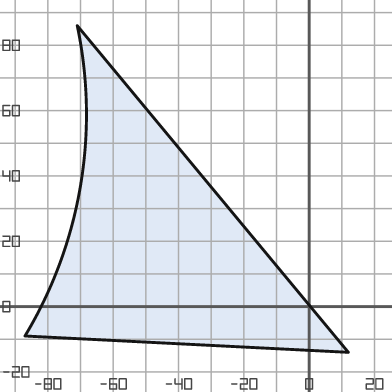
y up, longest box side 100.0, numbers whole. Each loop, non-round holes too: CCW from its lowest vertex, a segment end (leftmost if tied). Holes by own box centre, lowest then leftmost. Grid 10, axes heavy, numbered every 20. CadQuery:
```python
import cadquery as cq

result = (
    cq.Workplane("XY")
    .moveTo(12.0, -14.0)
    .lineTo(-71.0, 86.0)
    .threePointArc((-70.0, 37.0), (-87.0, -9.0))
    .close()
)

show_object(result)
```